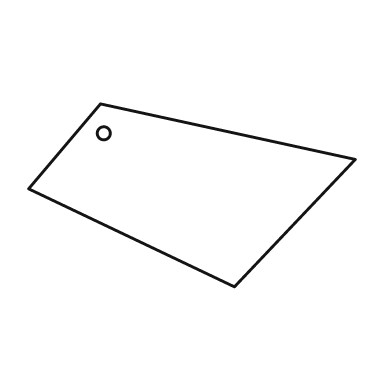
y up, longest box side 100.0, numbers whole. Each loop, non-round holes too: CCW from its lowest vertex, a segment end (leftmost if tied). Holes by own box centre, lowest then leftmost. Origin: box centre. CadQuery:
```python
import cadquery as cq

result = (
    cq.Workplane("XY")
    .moveTo(13.0, -28.0)
    .lineTo(50.0, 11.0)
    .lineTo(-28.0, 28.0)
    .lineTo(-50.0, 2.0)
    .close()
    .moveTo(-27.0, 19.0)
    .circle(2.0)
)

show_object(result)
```